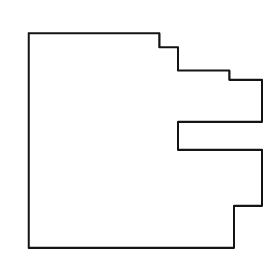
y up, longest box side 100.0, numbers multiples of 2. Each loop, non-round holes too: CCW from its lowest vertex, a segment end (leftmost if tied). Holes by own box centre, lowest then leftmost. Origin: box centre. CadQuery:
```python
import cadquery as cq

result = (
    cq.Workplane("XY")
    .moveTo(-50.0, -46.0)
    .lineTo(38.0, -46.0)
    .lineTo(38.0, -28.0)
    .lineTo(50.0, -28.0)
    .lineTo(50.0, -4.0)
    .lineTo(14.0, -4.0)
    .lineTo(14.0, 8.0)
    .lineTo(50.0, 8.0)
    .lineTo(50.0, 26.0)
    .lineTo(36.0, 26.0)
    .lineTo(36.0, 30.0)
    .lineTo(14.0, 30.0)
    .lineTo(14.0, 40.0)
    .lineTo(6.0, 40.0)
    .lineTo(6.0, 46.0)
    .lineTo(-50.0, 46.0)
    .close()
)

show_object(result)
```